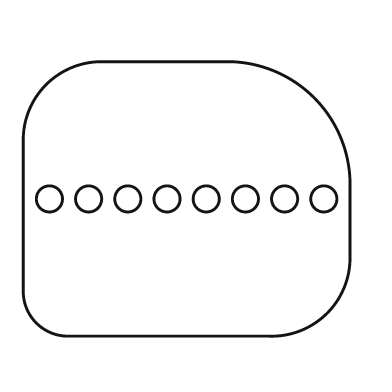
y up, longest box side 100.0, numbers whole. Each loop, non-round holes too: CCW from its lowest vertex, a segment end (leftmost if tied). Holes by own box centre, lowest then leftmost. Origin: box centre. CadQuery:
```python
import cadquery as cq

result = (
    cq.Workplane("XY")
    .moveTo(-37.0, -42.0)
    .lineTo(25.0, -42.0)
    .threePointArc((43.0, -35.0), (50.0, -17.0))
    .lineTo(50.0, 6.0)
    .threePointArc((39.0, 31.0), (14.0, 42.0))
    .lineTo(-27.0, 42.0)
    .threePointArc((-43.0, 35.0), (-50.0, 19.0))
    .lineTo(-50.0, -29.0)
    .threePointArc((-46.0, -38.0), (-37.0, -42.0))
    .close()
    .moveTo(-42.0, 0.0)
    .circle(4.0)
    .moveTo(-30.0, 0.0)
    .circle(4.0)
    .moveTo(-18.0, 0.0)
    .circle(4.0)
    .moveTo(-6.0, 0.0)
    .circle(4.0)
    .moveTo(6.0, 0.0)
    .circle(4.0)
    .moveTo(18.0, 0.0)
    .circle(4.0)
    .moveTo(30.0, 0.0)
    .circle(4.0)
    .moveTo(42.0, 0.0)
    .circle(4.0)
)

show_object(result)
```